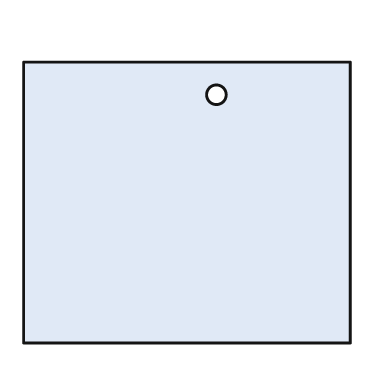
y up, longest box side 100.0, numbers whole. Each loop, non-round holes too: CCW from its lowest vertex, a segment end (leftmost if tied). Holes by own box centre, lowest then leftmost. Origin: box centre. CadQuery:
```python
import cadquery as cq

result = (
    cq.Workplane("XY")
    .moveTo(-50.0, -43.0)
    .lineTo(50.0, -43.0)
    .lineTo(50.0, 43.0)
    .lineTo(-50.0, 43.0)
    .close()
    .moveTo(9.0, 33.0)
    .circle(3.0)
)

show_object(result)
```